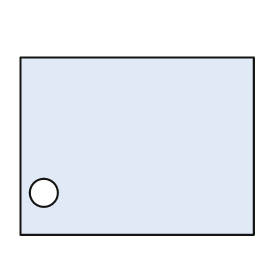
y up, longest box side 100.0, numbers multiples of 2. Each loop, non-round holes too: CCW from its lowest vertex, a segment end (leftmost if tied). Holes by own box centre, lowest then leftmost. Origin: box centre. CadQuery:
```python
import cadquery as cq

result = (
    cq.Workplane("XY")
    .moveTo(-50.0, -38.0)
    .lineTo(50.0, -38.0)
    .lineTo(50.0, 38.0)
    .lineTo(-50.0, 38.0)
    .close()
    .moveTo(-40.0, -20.0)
    .circle(6.0)
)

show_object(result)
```